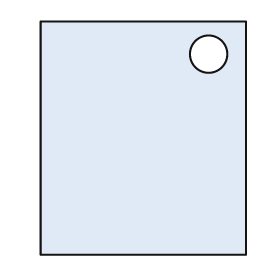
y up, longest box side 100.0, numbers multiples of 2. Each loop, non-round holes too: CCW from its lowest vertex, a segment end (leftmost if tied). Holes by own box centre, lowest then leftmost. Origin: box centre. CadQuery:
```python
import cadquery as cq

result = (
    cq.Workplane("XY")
    .moveTo(-44.0, -50.0)
    .lineTo(44.0, -50.0)
    .lineTo(44.0, 50.0)
    .lineTo(-44.0, 50.0)
    .close()
    .moveTo(28.0, 36.0)
    .circle(8.0)
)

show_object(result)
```